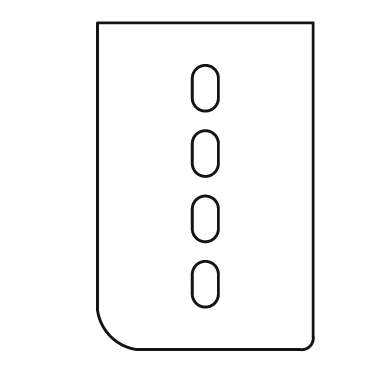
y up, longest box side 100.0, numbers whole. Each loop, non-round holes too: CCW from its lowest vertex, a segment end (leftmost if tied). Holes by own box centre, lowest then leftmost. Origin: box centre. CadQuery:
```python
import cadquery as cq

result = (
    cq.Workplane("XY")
    .moveTo(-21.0, -50.0)
    .lineTo(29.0, -50.0)
    .threePointArc((32.0, -49.0), (33.0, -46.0))
    .lineTo(33.0, 50.0)
    .lineTo(-33.0, 50.0)
    .lineTo(-33.0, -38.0)
    .threePointArc((-29.0, -46.0), (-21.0, -50.0))
    .close()
    .moveTo(-4.0, -33.0)
    .threePointArc((0.0, -37.0), (4.0, -33.0))
    .lineTo(4.0, -27.0)
    .threePointArc((0.0, -23.0), (-4.0, -27.0))
    .close()
    .moveTo(-4.0, -13.0)
    .threePointArc((0.0, -17.0), (4.0, -13.0))
    .lineTo(4.0, -7.0)
    .threePointArc((0.0, -3.0), (-4.0, -7.0))
    .close()
    .moveTo(-4.0, 7.0)
    .threePointArc((0.0, 3.0), (4.0, 7.0))
    .lineTo(4.0, 13.0)
    .threePointArc((0.0, 17.0), (-4.0, 13.0))
    .close()
    .moveTo(-4.0, 27.0)
    .threePointArc((0.0, 23.0), (4.0, 27.0))
    .lineTo(4.0, 33.0)
    .threePointArc((0.0, 37.0), (-4.0, 33.0))
    .close()
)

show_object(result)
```